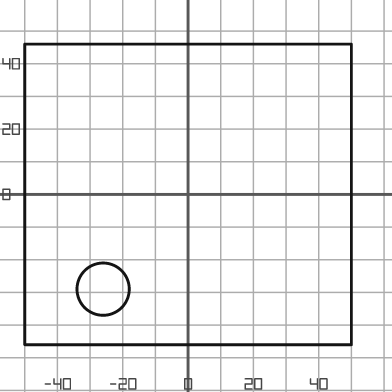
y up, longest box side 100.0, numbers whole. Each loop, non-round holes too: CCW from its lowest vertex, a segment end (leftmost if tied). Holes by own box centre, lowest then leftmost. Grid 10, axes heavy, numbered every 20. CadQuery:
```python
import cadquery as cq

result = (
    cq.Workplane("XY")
    .moveTo(-50.0, -46.0)
    .lineTo(50.0, -46.0)
    .lineTo(50.0, 46.0)
    .lineTo(-50.0, 46.0)
    .close()
    .moveTo(-26.0, -29.0)
    .circle(8.0)
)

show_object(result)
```